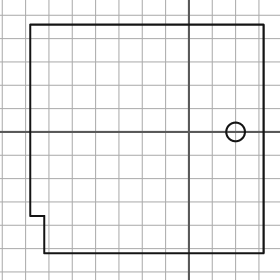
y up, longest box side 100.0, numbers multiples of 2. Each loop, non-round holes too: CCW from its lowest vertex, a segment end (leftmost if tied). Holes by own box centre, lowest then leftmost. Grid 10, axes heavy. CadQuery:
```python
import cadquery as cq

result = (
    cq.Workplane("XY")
    .moveTo(-62.0, -52.0)
    .lineTo(32.0, -52.0)
    .lineTo(32.0, 46.0)
    .lineTo(-68.0, 46.0)
    .lineTo(-68.0, -36.0)
    .lineTo(-62.0, -36.0)
    .close()
    .moveTo(20.0, 0.0)
    .circle(4.0)
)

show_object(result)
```